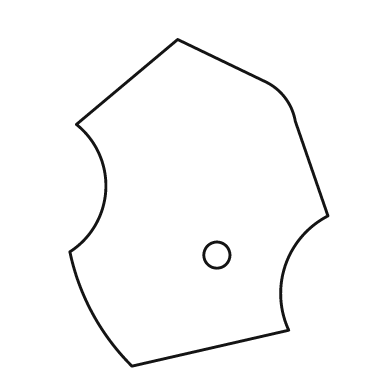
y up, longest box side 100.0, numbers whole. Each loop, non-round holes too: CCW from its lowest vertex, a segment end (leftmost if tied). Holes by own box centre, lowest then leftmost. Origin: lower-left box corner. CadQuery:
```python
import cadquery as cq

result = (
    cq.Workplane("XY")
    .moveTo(19.0, 0.0)
    .lineTo(67.0, 11.0)
    .threePointArc((66.0, 31.0), (79.0, 46.0))
    .lineTo(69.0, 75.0)
    .threePointArc((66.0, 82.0), (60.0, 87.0))
    .lineTo(33.0, 100.0)
    .lineTo(2.0, 74.0)
    .threePointArc((11.0, 54.0), (0.0, 35.0))
    .threePointArc((7.0, 16.0), (19.0, 0.0))
    .close()
    .moveTo(45.0, 34.0)
    .circle(4.0)
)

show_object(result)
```